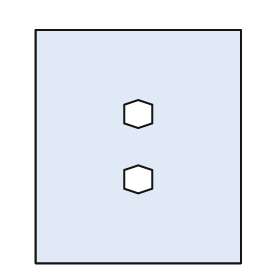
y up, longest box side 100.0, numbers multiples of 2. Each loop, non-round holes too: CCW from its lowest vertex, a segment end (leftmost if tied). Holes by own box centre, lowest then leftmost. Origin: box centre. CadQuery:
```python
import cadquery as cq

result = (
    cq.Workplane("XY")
    .moveTo(-44.0, -50.0)
    .lineTo(44.0, -50.0)
    .lineTo(44.0, 50.0)
    .lineTo(-44.0, 50.0)
    .close()
    .moveTo(0.0, -20.0)
    .lineTo(6.0, -18.0)
    .lineTo(6.0, -10.0)
    .lineTo(0.0, -8.0)
    .lineTo(-6.0, -10.0)
    .lineTo(-6.0, -18.0)
    .close()
    .moveTo(0.0, 8.0)
    .lineTo(6.0, 10.0)
    .lineTo(6.0, 18.0)
    .lineTo(0.0, 20.0)
    .lineTo(-6.0, 18.0)
    .lineTo(-6.0, 10.0)
    .close()
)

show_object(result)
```